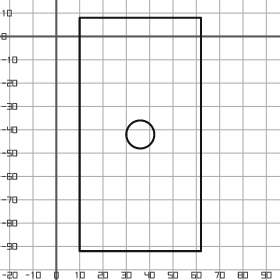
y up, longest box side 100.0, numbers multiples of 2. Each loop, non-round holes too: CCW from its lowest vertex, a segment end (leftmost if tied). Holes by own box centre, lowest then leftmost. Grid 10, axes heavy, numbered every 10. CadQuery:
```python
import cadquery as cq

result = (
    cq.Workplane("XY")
    .moveTo(10.0, -92.0)
    .lineTo(62.0, -92.0)
    .lineTo(62.0, 8.0)
    .lineTo(10.0, 8.0)
    .close()
    .moveTo(36.0, -42.0)
    .circle(6.0)
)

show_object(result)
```